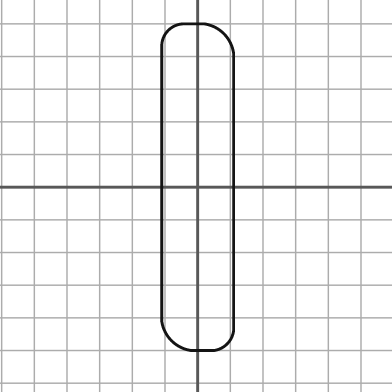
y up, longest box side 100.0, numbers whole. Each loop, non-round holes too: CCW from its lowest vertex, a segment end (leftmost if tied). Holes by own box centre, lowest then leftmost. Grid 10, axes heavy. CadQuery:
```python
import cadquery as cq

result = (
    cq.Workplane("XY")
    .moveTo(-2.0, -50.0)
    .lineTo(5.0, -50.0)
    .threePointArc((9.0, -48.0), (11.0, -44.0))
    .lineTo(11.0, 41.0)
    .threePointArc((8.0, 47.0), (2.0, 50.0))
    .lineTo(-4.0, 50.0)
    .threePointArc((-9.0, 48.0), (-11.0, 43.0))
    .lineTo(-11.0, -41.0)
    .threePointArc((-8.0, -47.0), (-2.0, -50.0))
    .close()
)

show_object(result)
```